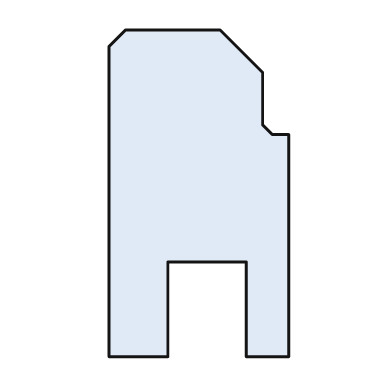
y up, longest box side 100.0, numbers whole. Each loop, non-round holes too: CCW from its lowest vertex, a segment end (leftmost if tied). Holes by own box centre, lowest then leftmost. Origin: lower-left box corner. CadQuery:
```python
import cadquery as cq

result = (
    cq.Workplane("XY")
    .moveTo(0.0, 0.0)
    .lineTo(18.0, 0.0)
    .lineTo(18.0, 29.0)
    .lineTo(42.0, 29.0)
    .lineTo(42.0, 0.0)
    .lineTo(55.0, 0.0)
    .lineTo(55.0, 68.0)
    .lineTo(50.0, 68.0)
    .lineTo(47.0, 71.0)
    .lineTo(47.0, 87.0)
    .lineTo(34.0, 100.0)
    .lineTo(5.0, 100.0)
    .lineTo(0.0, 95.0)
    .close()
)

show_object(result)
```